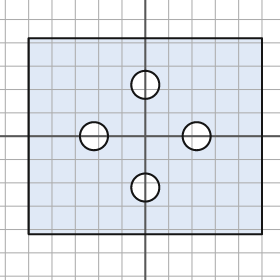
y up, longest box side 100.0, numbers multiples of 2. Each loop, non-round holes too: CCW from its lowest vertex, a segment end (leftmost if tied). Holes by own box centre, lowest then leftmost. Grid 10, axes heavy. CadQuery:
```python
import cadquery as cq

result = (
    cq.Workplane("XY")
    .moveTo(-50.0, -42.0)
    .lineTo(50.0, -42.0)
    .lineTo(50.0, 42.0)
    .lineTo(-50.0, 42.0)
    .close()
    .moveTo(0.0, -22.0)
    .circle(6.0)
    .moveTo(-22.0, 0.0)
    .circle(6.0)
    .moveTo(22.0, 0.0)
    .circle(6.0)
    .moveTo(0.0, 22.0)
    .circle(6.0)
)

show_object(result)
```